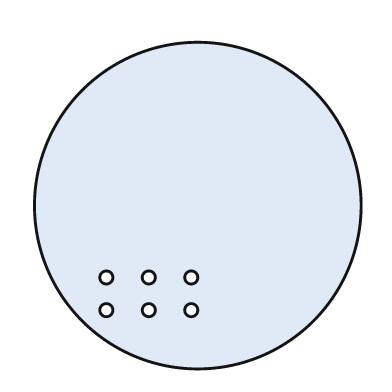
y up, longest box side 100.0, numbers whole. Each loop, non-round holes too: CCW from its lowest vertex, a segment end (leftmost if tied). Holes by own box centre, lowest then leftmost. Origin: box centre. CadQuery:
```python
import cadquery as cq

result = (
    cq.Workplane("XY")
    .moveTo(0.0, 0.0)
    .circle(50.0)
    .moveTo(-28.0, -32.0)
    .circle(2.0)
    .moveTo(-15.0, -32.0)
    .circle(2.0)
    .moveTo(-2.0, -32.0)
    .circle(2.0)
    .moveTo(-28.0, -22.0)
    .circle(2.0)
    .moveTo(-15.0, -22.0)
    .circle(2.0)
    .moveTo(-2.0, -22.0)
    .circle(2.0)
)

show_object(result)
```